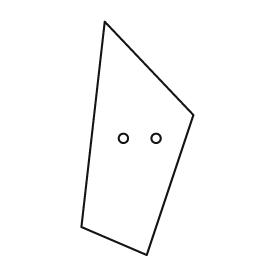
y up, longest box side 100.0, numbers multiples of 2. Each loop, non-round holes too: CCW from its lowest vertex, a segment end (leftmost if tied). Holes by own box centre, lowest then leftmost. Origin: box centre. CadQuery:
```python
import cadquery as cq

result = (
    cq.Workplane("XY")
    .moveTo(4.0, -50.0)
    .lineTo(24.0, 10.0)
    .lineTo(-14.0, 50.0)
    .lineTo(-24.0, -38.0)
    .close()
    .moveTo(-6.0, 0.0)
    .circle(2.0)
    .moveTo(8.0, 0.0)
    .circle(2.0)
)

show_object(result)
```